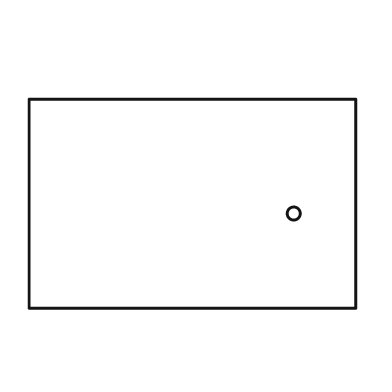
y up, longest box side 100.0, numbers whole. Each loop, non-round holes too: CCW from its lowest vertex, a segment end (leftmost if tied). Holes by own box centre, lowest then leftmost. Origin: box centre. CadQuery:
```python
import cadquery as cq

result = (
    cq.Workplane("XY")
    .moveTo(-50.0, -32.0)
    .lineTo(50.0, -32.0)
    .lineTo(50.0, 32.0)
    .lineTo(-50.0, 32.0)
    .close()
    .moveTo(31.0, -3.0)
    .circle(2.0)
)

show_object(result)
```